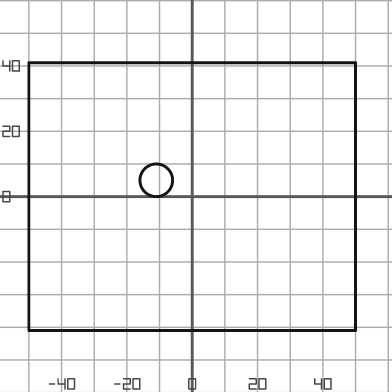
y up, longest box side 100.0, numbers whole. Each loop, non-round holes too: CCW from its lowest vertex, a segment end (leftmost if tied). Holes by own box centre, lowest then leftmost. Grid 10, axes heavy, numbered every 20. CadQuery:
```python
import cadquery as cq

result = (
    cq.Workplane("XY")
    .moveTo(-50.0, -41.0)
    .lineTo(50.0, -41.0)
    .lineTo(50.0, 41.0)
    .lineTo(-50.0, 41.0)
    .close()
    .moveTo(-11.0, 5.0)
    .circle(5.0)
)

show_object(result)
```